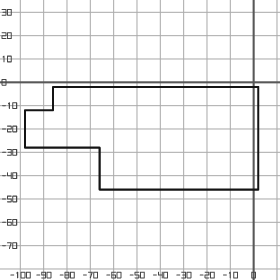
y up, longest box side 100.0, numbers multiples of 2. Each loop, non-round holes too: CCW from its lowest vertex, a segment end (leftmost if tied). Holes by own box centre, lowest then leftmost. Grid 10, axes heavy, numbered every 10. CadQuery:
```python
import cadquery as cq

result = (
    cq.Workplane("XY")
    .moveTo(-66.0, -46.0)
    .lineTo(2.0, -46.0)
    .lineTo(2.0, -2.0)
    .lineTo(-86.0, -2.0)
    .lineTo(-86.0, -12.0)
    .lineTo(-98.0, -12.0)
    .lineTo(-98.0, -28.0)
    .lineTo(-66.0, -28.0)
    .close()
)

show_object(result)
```